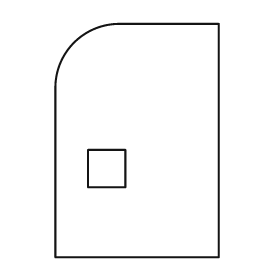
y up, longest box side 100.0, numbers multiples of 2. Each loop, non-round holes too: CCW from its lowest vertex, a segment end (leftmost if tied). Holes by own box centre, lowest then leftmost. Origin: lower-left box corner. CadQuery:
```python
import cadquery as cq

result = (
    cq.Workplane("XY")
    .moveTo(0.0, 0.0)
    .lineTo(70.0, 0.0)
    .lineTo(70.0, 100.0)
    .lineTo(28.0, 100.0)
    .threePointArc((8.0, 92.0), (0.0, 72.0))
    .close()
    .moveTo(14.0, 30.0)
    .lineTo(30.0, 30.0)
    .lineTo(30.0, 46.0)
    .lineTo(14.0, 46.0)
    .close()
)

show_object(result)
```